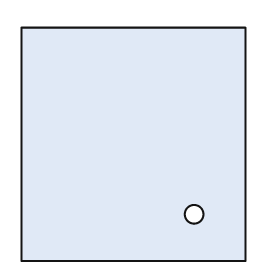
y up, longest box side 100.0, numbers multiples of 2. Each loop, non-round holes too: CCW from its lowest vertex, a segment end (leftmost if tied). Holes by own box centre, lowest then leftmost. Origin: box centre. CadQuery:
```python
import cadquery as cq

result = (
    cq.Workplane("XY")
    .moveTo(-48.0, -50.0)
    .lineTo(48.0, -50.0)
    .lineTo(48.0, 50.0)
    .lineTo(-48.0, 50.0)
    .close()
    .moveTo(26.0, -30.0)
    .circle(4.0)
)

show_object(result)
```